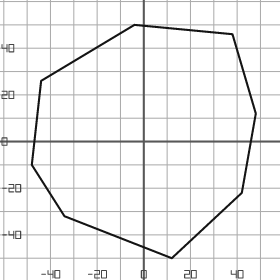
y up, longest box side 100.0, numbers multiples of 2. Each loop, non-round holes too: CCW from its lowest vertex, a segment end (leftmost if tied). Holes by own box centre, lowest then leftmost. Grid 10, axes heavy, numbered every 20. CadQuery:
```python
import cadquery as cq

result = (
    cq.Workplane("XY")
    .moveTo(12.0, -50.0)
    .lineTo(42.0, -22.0)
    .lineTo(48.0, 12.0)
    .lineTo(38.0, 46.0)
    .lineTo(-4.0, 50.0)
    .lineTo(-44.0, 26.0)
    .lineTo(-48.0, -10.0)
    .lineTo(-34.0, -32.0)
    .close()
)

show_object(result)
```